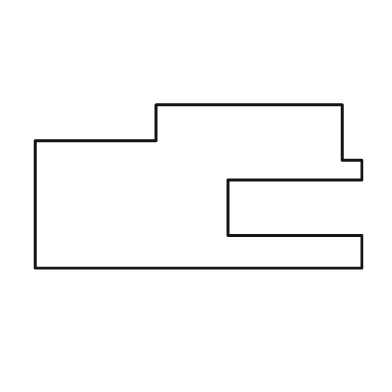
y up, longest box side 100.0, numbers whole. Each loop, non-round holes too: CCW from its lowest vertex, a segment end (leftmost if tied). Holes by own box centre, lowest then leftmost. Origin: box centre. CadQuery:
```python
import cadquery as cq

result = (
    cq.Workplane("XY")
    .moveTo(-50.0, -25.0)
    .lineTo(50.0, -25.0)
    .lineTo(50.0, -15.0)
    .lineTo(9.0, -15.0)
    .lineTo(9.0, 2.0)
    .lineTo(50.0, 2.0)
    .lineTo(50.0, 8.0)
    .lineTo(44.0, 8.0)
    .lineTo(44.0, 25.0)
    .lineTo(-13.0, 25.0)
    .lineTo(-13.0, 14.0)
    .lineTo(-50.0, 14.0)
    .close()
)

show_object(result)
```